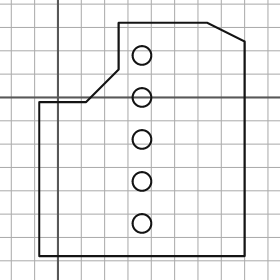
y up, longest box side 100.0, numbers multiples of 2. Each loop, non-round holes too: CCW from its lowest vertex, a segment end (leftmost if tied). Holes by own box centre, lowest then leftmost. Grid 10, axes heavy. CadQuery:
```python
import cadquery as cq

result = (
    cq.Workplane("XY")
    .moveTo(-8.0, -68.0)
    .lineTo(80.0, -68.0)
    .lineTo(80.0, 24.0)
    .lineTo(64.0, 32.0)
    .lineTo(26.0, 32.0)
    .lineTo(26.0, 12.0)
    .lineTo(12.0, -2.0)
    .lineTo(-8.0, -2.0)
    .close()
    .moveTo(36.0, -54.0)
    .circle(4.0)
    .moveTo(36.0, -36.0)
    .circle(4.0)
    .moveTo(36.0, -18.0)
    .circle(4.0)
    .moveTo(36.0, 0.0)
    .circle(4.0)
    .moveTo(36.0, 18.0)
    .circle(4.0)
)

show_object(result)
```